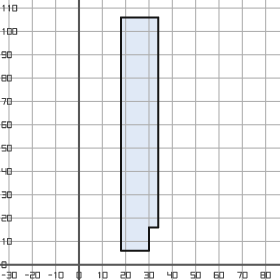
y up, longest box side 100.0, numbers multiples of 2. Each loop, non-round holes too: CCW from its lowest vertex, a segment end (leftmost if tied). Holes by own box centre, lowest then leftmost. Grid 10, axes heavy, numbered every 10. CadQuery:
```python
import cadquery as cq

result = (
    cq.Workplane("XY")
    .moveTo(18.0, 6.0)
    .lineTo(30.0, 6.0)
    .lineTo(30.0, 16.0)
    .lineTo(34.0, 16.0)
    .lineTo(34.0, 106.0)
    .lineTo(18.0, 106.0)
    .close()
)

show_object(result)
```